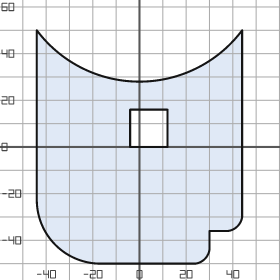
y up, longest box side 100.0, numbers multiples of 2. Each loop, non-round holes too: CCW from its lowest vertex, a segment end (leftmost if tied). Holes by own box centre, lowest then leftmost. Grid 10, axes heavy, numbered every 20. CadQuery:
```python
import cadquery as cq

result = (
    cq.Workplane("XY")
    .moveTo(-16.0, -50.0)
    .lineTo(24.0, -50.0)
    .threePointArc((28.0, -48.0), (30.0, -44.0))
    .lineTo(30.0, -36.0)
    .lineTo(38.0, -36.0)
    .threePointArc((42.0, -34.0), (44.0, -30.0))
    .lineTo(44.0, 50.0)
    .threePointArc((0.0, 28.0), (-44.0, 50.0))
    .lineTo(-44.0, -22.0)
    .threePointArc((-36.0, -42.0), (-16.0, -50.0))
    .close()
    .moveTo(-4.0, 0.0)
    .lineTo(12.0, 0.0)
    .lineTo(12.0, 16.0)
    .lineTo(-4.0, 16.0)
    .close()
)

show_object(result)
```